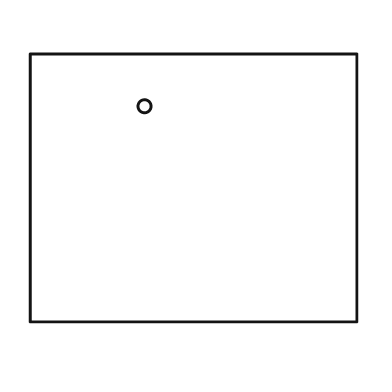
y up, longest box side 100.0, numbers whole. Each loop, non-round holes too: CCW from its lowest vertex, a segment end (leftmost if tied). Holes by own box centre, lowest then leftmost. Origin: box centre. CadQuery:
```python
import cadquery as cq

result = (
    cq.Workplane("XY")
    .moveTo(-50.0, -41.0)
    .lineTo(50.0, -41.0)
    .lineTo(50.0, 41.0)
    .lineTo(-50.0, 41.0)
    .close()
    .moveTo(-15.0, 25.0)
    .circle(2.0)
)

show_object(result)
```